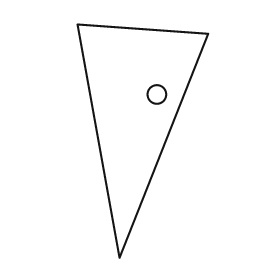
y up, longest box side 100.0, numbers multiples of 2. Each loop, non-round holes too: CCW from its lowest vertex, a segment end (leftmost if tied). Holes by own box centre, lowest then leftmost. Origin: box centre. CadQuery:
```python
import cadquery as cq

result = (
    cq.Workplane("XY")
    .moveTo(-10.0, -50.0)
    .lineTo(28.0, 46.0)
    .lineTo(-28.0, 50.0)
    .close()
    .moveTo(6.0, 20.0)
    .circle(4.0)
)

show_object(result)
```